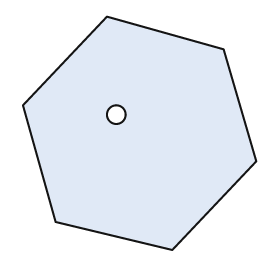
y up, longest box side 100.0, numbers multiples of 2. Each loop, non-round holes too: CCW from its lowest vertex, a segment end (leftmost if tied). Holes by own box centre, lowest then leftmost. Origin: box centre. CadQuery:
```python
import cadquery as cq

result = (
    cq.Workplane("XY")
    .moveTo(14.0, -50.0)
    .lineTo(50.0, -12.0)
    .lineTo(36.0, 36.0)
    .lineTo(-14.0, 50.0)
    .lineTo(-50.0, 12.0)
    .lineTo(-36.0, -38.0)
    .close()
    .moveTo(-10.0, 8.0)
    .circle(4.0)
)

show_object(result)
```